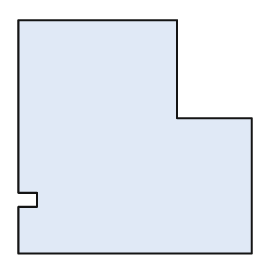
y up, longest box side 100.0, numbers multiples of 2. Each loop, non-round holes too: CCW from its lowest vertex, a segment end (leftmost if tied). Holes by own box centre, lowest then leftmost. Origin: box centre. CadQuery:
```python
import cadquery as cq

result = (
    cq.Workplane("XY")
    .moveTo(-50.0, -50.0)
    .lineTo(50.0, -50.0)
    .lineTo(50.0, 8.0)
    .lineTo(18.0, 8.0)
    .lineTo(18.0, 50.0)
    .lineTo(-50.0, 50.0)
    .lineTo(-50.0, -24.0)
    .lineTo(-42.0, -24.0)
    .lineTo(-42.0, -30.0)
    .lineTo(-50.0, -30.0)
    .close()
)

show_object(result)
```